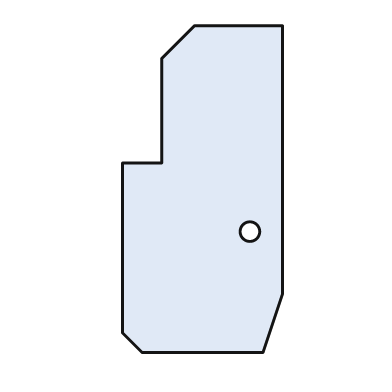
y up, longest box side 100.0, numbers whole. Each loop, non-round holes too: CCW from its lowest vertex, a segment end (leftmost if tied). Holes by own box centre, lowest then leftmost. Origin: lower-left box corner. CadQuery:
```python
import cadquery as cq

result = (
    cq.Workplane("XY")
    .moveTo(6.0, 0.0)
    .lineTo(43.0, 0.0)
    .lineTo(49.0, 18.0)
    .lineTo(49.0, 100.0)
    .lineTo(22.0, 100.0)
    .lineTo(12.0, 90.0)
    .lineTo(12.0, 58.0)
    .lineTo(0.0, 58.0)
    .lineTo(0.0, 6.0)
    .close()
    .moveTo(39.0, 37.0)
    .circle(3.0)
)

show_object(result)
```